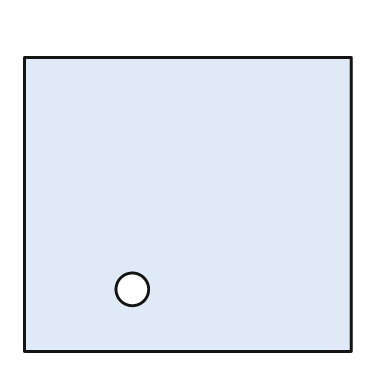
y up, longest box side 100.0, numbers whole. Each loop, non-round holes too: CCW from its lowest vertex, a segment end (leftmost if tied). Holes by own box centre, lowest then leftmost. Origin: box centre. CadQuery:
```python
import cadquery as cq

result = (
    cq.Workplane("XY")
    .moveTo(-50.0, -45.0)
    .lineTo(50.0, -45.0)
    .lineTo(50.0, 45.0)
    .lineTo(-50.0, 45.0)
    .close()
    .moveTo(-17.0, -26.0)
    .circle(5.0)
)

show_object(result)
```